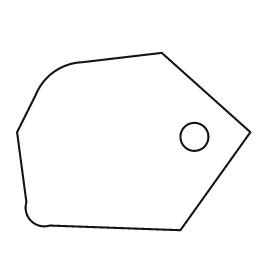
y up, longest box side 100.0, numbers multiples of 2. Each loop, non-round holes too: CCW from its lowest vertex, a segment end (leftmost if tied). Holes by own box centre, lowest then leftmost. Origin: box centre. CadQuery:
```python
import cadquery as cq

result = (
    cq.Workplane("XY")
    .moveTo(20.0, -38.0)
    .lineTo(50.0, 4.0)
    .lineTo(12.0, 38.0)
    .lineTo(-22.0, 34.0)
    .threePointArc((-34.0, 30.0), (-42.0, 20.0))
    .lineTo(-50.0, 4.0)
    .lineTo(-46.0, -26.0)
    .threePointArc((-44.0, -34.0), (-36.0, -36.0))
    .close()
    .moveTo(26.0, 2.0)
    .circle(6.0)
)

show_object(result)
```